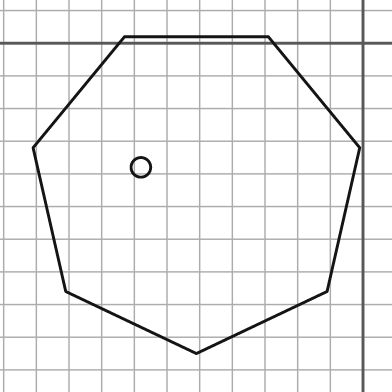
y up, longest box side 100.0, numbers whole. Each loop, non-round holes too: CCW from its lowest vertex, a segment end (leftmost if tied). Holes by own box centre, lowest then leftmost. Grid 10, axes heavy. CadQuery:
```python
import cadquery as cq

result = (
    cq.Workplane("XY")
    .moveTo(-51.0, -95.0)
    .lineTo(-11.0, -76.0)
    .lineTo(-1.0, -32.0)
    .lineTo(-29.0, 2.0)
    .lineTo(-73.0, 2.0)
    .lineTo(-101.0, -32.0)
    .lineTo(-91.0, -76.0)
    .close()
    .moveTo(-68.0, -38.0)
    .circle(3.0)
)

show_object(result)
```